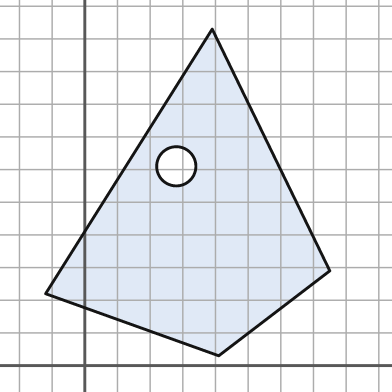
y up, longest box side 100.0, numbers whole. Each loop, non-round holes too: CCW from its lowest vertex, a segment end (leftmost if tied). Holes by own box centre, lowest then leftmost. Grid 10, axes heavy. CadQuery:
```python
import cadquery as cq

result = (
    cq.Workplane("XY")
    .moveTo(41.0, 3.0)
    .lineTo(75.0, 29.0)
    .lineTo(39.0, 103.0)
    .lineTo(-12.0, 22.0)
    .close()
    .moveTo(28.0, 61.0)
    .circle(6.0)
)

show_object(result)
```